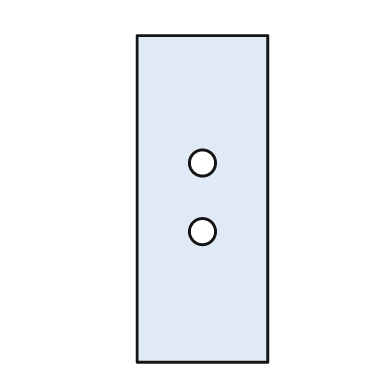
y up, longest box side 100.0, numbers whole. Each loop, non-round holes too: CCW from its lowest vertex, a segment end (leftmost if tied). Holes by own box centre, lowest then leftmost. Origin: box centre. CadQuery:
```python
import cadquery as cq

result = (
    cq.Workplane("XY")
    .moveTo(-20.0, -50.0)
    .lineTo(20.0, -50.0)
    .lineTo(20.0, 50.0)
    .lineTo(-20.0, 50.0)
    .close()
    .moveTo(0.0, -10.0)
    .circle(4.0)
    .moveTo(0.0, 11.0)
    .circle(4.0)
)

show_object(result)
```